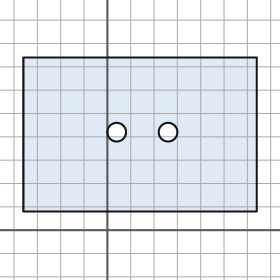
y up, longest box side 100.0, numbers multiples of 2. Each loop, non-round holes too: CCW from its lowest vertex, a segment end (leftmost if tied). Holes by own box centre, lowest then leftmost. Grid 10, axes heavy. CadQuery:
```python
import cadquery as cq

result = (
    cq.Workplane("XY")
    .moveTo(-36.0, 8.0)
    .lineTo(64.0, 8.0)
    .lineTo(64.0, 74.0)
    .lineTo(-36.0, 74.0)
    .close()
    .moveTo(4.0, 42.0)
    .circle(4.0)
    .moveTo(26.0, 42.0)
    .circle(4.0)
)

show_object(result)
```